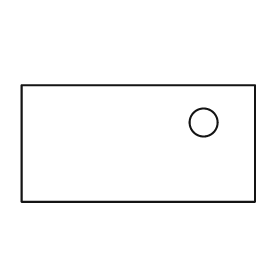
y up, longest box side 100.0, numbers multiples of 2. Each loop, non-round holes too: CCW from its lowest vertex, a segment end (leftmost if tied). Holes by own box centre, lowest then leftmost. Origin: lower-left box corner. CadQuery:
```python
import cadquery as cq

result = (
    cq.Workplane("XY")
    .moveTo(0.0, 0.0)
    .lineTo(100.0, 0.0)
    .lineTo(100.0, 50.0)
    .lineTo(0.0, 50.0)
    .close()
    .moveTo(78.0, 34.0)
    .circle(6.0)
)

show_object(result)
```